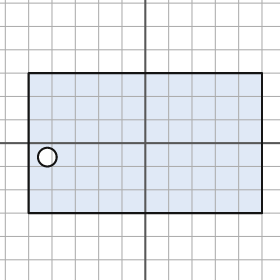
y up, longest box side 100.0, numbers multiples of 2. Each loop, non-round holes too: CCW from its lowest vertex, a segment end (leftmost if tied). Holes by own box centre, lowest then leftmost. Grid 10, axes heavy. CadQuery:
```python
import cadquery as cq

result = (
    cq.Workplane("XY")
    .moveTo(-50.0, -30.0)
    .lineTo(50.0, -30.0)
    .lineTo(50.0, 30.0)
    .lineTo(-50.0, 30.0)
    .close()
    .moveTo(-42.0, -6.0)
    .circle(4.0)
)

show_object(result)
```